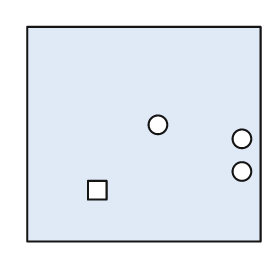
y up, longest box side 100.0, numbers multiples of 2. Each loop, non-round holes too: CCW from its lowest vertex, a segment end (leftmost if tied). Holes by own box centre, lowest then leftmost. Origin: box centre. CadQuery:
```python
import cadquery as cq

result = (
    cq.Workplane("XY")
    .moveTo(-50.0, -46.0)
    .lineTo(50.0, -46.0)
    .lineTo(50.0, 46.0)
    .lineTo(-50.0, 46.0)
    .close()
    .moveTo(-24.0, -28.0)
    .lineTo(-16.0, -28.0)
    .lineTo(-16.0, -20.0)
    .lineTo(-24.0, -20.0)
    .close()
    .moveTo(42.0, -16.0)
    .circle(4.0)
    .moveTo(42.0, -2.0)
    .circle(4.0)
    .moveTo(6.0, 4.0)
    .circle(4.0)
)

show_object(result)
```